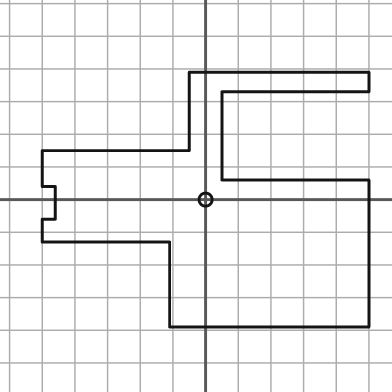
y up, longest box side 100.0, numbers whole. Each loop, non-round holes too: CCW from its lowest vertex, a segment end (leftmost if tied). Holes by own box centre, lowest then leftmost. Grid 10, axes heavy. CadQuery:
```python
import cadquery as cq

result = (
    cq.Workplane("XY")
    .moveTo(-11.0, -39.0)
    .lineTo(50.0, -39.0)
    .lineTo(50.0, 6.0)
    .lineTo(5.0, 6.0)
    .lineTo(5.0, 33.0)
    .lineTo(50.0, 33.0)
    .lineTo(50.0, 39.0)
    .lineTo(-5.0, 39.0)
    .lineTo(-5.0, 15.0)
    .lineTo(-50.0, 15.0)
    .lineTo(-50.0, 4.0)
    .lineTo(-46.0, 4.0)
    .lineTo(-46.0, -6.0)
    .lineTo(-50.0, -6.0)
    .lineTo(-50.0, -13.0)
    .lineTo(-11.0, -13.0)
    .close()
    .moveTo(0.0, 0.0)
    .circle(2.0)
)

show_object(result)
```